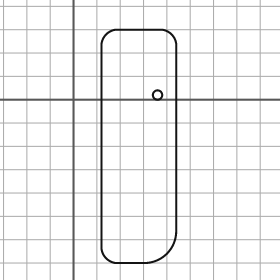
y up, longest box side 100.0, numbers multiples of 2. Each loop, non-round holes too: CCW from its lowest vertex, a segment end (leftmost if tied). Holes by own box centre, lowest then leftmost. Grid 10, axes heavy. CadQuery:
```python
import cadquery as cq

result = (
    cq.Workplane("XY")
    .moveTo(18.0, -70.0)
    .lineTo(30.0, -70.0)
    .threePointArc((40.0, -66.0), (44.0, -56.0))
    .lineTo(44.0, 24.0)
    .threePointArc((42.0, 28.0), (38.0, 30.0))
    .lineTo(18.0, 30.0)
    .threePointArc((14.0, 28.0), (12.0, 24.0))
    .lineTo(12.0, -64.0)
    .threePointArc((14.0, -68.0), (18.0, -70.0))
    .close()
    .moveTo(36.0, 2.0)
    .circle(2.0)
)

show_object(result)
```